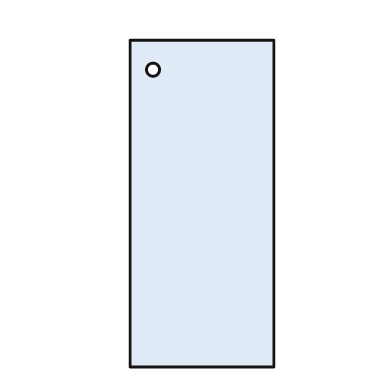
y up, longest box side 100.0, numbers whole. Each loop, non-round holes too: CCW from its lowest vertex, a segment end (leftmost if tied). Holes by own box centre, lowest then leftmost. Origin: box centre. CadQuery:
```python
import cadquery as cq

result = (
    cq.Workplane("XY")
    .moveTo(-22.0, -50.0)
    .lineTo(22.0, -50.0)
    .lineTo(22.0, 50.0)
    .lineTo(-22.0, 50.0)
    .close()
    .moveTo(-15.0, 41.0)
    .circle(2.0)
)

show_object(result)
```